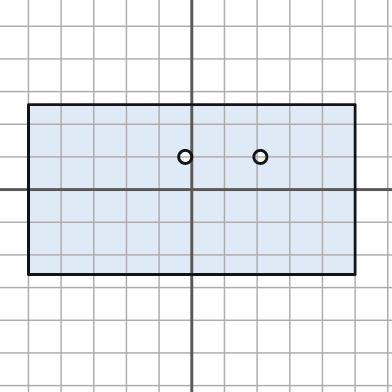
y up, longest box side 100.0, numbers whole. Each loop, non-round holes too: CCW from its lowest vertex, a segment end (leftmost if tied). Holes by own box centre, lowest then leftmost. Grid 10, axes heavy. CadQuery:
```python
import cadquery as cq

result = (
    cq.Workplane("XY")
    .moveTo(-50.0, -26.0)
    .lineTo(50.0, -26.0)
    .lineTo(50.0, 26.0)
    .lineTo(-50.0, 26.0)
    .close()
    .moveTo(-2.0, 10.0)
    .circle(2.0)
    .moveTo(21.0, 10.0)
    .circle(2.0)
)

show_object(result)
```